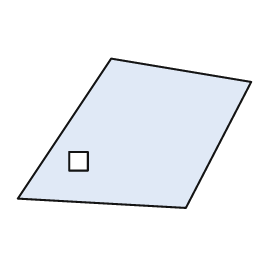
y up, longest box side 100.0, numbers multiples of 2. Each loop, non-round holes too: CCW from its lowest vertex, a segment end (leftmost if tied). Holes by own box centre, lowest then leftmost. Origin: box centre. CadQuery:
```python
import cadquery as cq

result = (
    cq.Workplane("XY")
    .moveTo(22.0, -32.0)
    .lineTo(50.0, 22.0)
    .lineTo(-10.0, 32.0)
    .lineTo(-50.0, -28.0)
    .close()
    .moveTo(-28.0, -16.0)
    .lineTo(-20.0, -16.0)
    .lineTo(-20.0, -8.0)
    .lineTo(-28.0, -8.0)
    .close()
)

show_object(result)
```